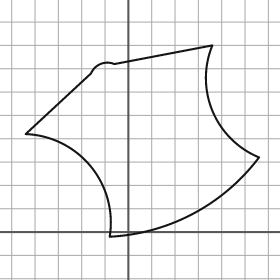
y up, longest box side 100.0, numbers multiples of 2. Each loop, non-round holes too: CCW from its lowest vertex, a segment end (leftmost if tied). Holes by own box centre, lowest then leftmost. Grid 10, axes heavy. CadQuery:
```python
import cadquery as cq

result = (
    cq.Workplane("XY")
    .moveTo(-8.0, -2.0)
    .threePointArc((28.0, 8.0), (56.0, 32.0))
    .threePointArc((36.0, 52.0), (36.0, 80.0))
    .lineTo(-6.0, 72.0)
    .threePointArc((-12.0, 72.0), (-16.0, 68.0))
    .lineTo(-44.0, 42.0)
    .threePointArc((-16.0, 28.0), (-8.0, -2.0))
    .close()
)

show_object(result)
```